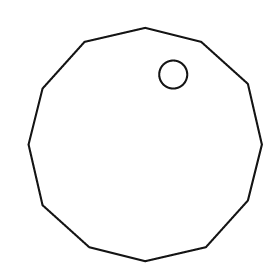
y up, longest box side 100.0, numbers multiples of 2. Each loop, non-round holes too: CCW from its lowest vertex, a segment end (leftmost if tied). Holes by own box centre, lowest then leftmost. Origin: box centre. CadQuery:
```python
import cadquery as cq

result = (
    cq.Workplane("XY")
    .moveTo(0.0, -50.0)
    .lineTo(26.0, -44.0)
    .lineTo(44.0, -24.0)
    .lineTo(50.0, 0.0)
    .lineTo(44.0, 26.0)
    .lineTo(24.0, 44.0)
    .lineTo(0.0, 50.0)
    .lineTo(-26.0, 44.0)
    .lineTo(-44.0, 24.0)
    .lineTo(-50.0, 0.0)
    .lineTo(-44.0, -26.0)
    .lineTo(-24.0, -44.0)
    .close()
    .moveTo(12.0, 30.0)
    .circle(6.0)
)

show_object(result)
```